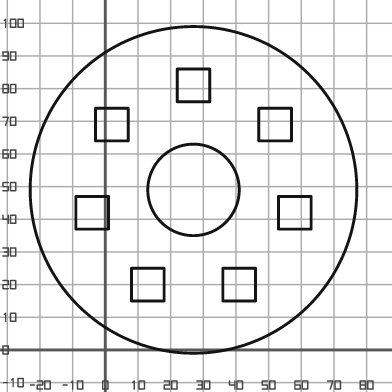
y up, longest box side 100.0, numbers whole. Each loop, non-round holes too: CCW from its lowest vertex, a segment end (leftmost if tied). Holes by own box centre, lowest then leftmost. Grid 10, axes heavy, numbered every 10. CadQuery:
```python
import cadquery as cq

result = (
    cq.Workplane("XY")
    .moveTo(27.0, 49.0)
    .circle(50.0)
    .moveTo(8.0, 15.0)
    .lineTo(18.0, 15.0)
    .lineTo(18.0, 25.0)
    .lineTo(8.0, 25.0)
    .close()
    .moveTo(36.0, 15.0)
    .lineTo(46.0, 15.0)
    .lineTo(46.0, 25.0)
    .lineTo(36.0, 25.0)
    .close()
    .moveTo(-9.0, 37.0)
    .lineTo(1.0, 37.0)
    .lineTo(1.0, 47.0)
    .lineTo(-9.0, 47.0)
    .close()
    .moveTo(53.0, 37.0)
    .lineTo(63.0, 37.0)
    .lineTo(63.0, 47.0)
    .lineTo(53.0, 47.0)
    .close()
    .moveTo(27.0, 49.0)
    .circle(14.0)
    .moveTo(-3.0, 64.0)
    .lineTo(7.0, 64.0)
    .lineTo(7.0, 74.0)
    .lineTo(-3.0, 74.0)
    .close()
    .moveTo(47.0, 64.0)
    .lineTo(57.0, 64.0)
    .lineTo(57.0, 74.0)
    .lineTo(47.0, 74.0)
    .close()
    .moveTo(22.0, 76.0)
    .lineTo(32.0, 76.0)
    .lineTo(32.0, 86.0)
    .lineTo(22.0, 86.0)
    .close()
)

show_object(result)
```